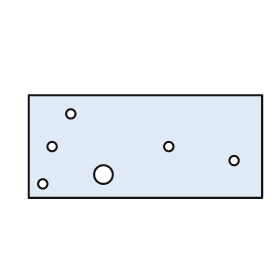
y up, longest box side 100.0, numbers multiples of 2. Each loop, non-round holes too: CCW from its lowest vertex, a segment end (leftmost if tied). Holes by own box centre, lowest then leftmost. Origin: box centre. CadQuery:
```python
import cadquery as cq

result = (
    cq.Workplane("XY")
    .moveTo(-50.0, -22.0)
    .lineTo(50.0, -22.0)
    .lineTo(50.0, 22.0)
    .lineTo(-50.0, 22.0)
    .close()
    .moveTo(-44.0, -16.0)
    .circle(2.0)
    .moveTo(-18.0, -12.0)
    .circle(4.0)
    .moveTo(38.0, -6.0)
    .circle(2.0)
    .moveTo(-40.0, 0.0)
    .circle(2.0)
    .moveTo(10.0, 0.0)
    .circle(2.0)
    .moveTo(-32.0, 14.0)
    .circle(2.0)
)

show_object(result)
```